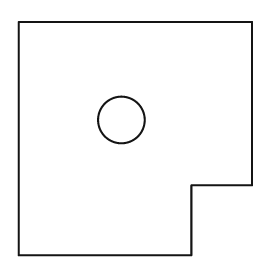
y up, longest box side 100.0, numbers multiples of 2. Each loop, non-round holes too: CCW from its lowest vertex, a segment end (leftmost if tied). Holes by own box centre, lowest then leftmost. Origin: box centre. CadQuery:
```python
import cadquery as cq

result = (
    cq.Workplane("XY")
    .moveTo(-50.0, -50.0)
    .lineTo(24.0, -50.0)
    .lineTo(24.0, -20.0)
    .lineTo(50.0, -20.0)
    .lineTo(50.0, 50.0)
    .lineTo(-50.0, 50.0)
    .close()
    .moveTo(-6.0, 8.0)
    .circle(10.0)
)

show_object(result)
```